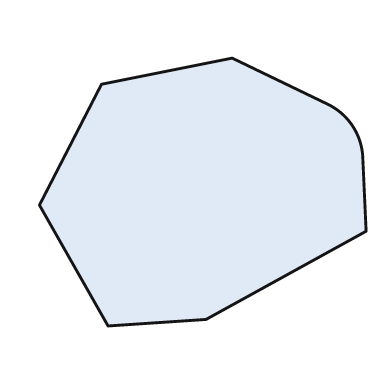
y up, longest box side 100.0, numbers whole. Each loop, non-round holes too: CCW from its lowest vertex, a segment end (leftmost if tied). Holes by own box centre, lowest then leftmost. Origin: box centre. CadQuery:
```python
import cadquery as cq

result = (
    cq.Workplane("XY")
    .moveTo(-29.0, -41.0)
    .lineTo(1.0, -39.0)
    .lineTo(50.0, -12.0)
    .lineTo(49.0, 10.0)
    .threePointArc((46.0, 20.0), (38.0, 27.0))
    .lineTo(9.0, 41.0)
    .lineTo(-31.0, 33.0)
    .lineTo(-50.0, -4.0)
    .close()
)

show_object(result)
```